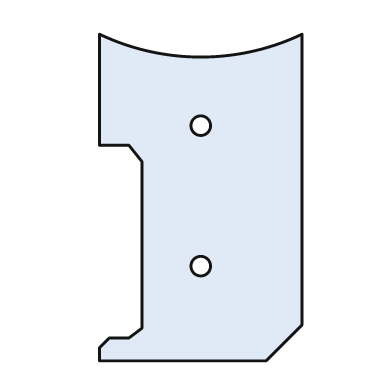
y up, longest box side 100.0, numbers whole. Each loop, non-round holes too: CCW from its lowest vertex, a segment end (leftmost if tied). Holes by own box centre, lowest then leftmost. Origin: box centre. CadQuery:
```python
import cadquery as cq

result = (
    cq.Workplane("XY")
    .moveTo(-31.0, -50.0)
    .lineTo(20.0, -50.0)
    .lineTo(31.0, -39.0)
    .lineTo(31.0, 50.0)
    .threePointArc((0.0, 43.0), (-31.0, 50.0))
    .lineTo(-31.0, 16.0)
    .lineTo(-22.0, 16.0)
    .lineTo(-18.0, 11.0)
    .lineTo(-18.0, -40.0)
    .lineTo(-22.0, -43.0)
    .lineTo(-28.0, -43.0)
    .lineTo(-31.0, -46.0)
    .close()
    .moveTo(0.0, -21.0)
    .circle(3.0)
    .moveTo(0.0, 22.0)
    .circle(3.0)
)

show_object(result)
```